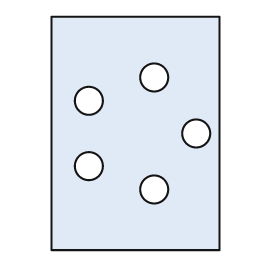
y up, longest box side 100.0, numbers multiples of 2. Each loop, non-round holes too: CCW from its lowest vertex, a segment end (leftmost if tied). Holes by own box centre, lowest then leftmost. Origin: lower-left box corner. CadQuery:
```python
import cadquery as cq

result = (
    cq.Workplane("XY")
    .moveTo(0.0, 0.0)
    .lineTo(72.0, 0.0)
    .lineTo(72.0, 100.0)
    .lineTo(0.0, 100.0)
    .close()
    .moveTo(44.0, 26.0)
    .circle(6.0)
    .moveTo(16.0, 36.0)
    .circle(6.0)
    .moveTo(62.0, 50.0)
    .circle(6.0)
    .moveTo(16.0, 64.0)
    .circle(6.0)
    .moveTo(44.0, 74.0)
    .circle(6.0)
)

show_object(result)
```